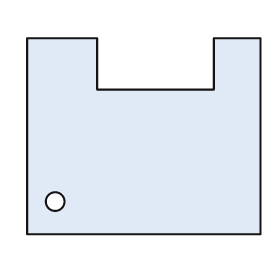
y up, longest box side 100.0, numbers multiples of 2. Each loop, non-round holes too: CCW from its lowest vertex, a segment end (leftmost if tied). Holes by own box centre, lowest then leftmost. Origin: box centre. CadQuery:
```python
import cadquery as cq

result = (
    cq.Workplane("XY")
    .moveTo(-50.0, -42.0)
    .lineTo(50.0, -42.0)
    .lineTo(50.0, 42.0)
    .lineTo(30.0, 42.0)
    .lineTo(30.0, 20.0)
    .lineTo(-20.0, 20.0)
    .lineTo(-20.0, 42.0)
    .lineTo(-50.0, 42.0)
    .close()
    .moveTo(-38.0, -28.0)
    .circle(4.0)
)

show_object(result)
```